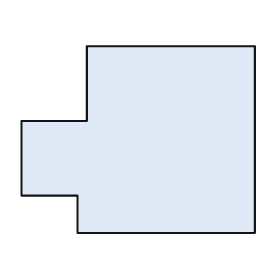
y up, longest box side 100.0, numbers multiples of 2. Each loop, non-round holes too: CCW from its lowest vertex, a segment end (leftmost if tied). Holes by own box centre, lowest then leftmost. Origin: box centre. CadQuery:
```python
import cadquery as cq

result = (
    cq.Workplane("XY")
    .moveTo(-26.0, -40.0)
    .lineTo(50.0, -40.0)
    .lineTo(50.0, 40.0)
    .lineTo(-22.0, 40.0)
    .lineTo(-22.0, 8.0)
    .lineTo(-50.0, 8.0)
    .lineTo(-50.0, -24.0)
    .lineTo(-26.0, -24.0)
    .close()
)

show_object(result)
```